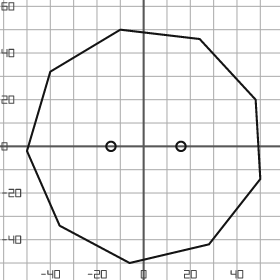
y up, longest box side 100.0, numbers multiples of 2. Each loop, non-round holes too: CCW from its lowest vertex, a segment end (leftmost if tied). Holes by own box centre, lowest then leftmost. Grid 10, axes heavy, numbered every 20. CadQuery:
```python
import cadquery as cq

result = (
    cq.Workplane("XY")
    .moveTo(-6.0, -50.0)
    .lineTo(28.0, -42.0)
    .lineTo(50.0, -14.0)
    .lineTo(48.0, 20.0)
    .lineTo(24.0, 46.0)
    .lineTo(-10.0, 50.0)
    .lineTo(-40.0, 32.0)
    .lineTo(-50.0, -2.0)
    .lineTo(-36.0, -34.0)
    .close()
    .moveTo(-14.0, 0.0)
    .circle(2.0)
    .moveTo(16.0, 0.0)
    .circle(2.0)
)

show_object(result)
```